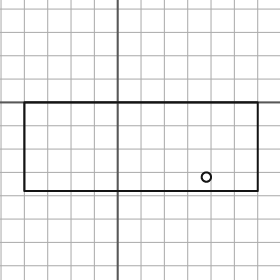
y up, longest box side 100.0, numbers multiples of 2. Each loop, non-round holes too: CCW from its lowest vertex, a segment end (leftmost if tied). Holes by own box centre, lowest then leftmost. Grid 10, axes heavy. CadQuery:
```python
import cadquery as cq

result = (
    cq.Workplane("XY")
    .moveTo(-40.0, -38.0)
    .lineTo(60.0, -38.0)
    .lineTo(60.0, 0.0)
    .lineTo(-40.0, 0.0)
    .close()
    .moveTo(38.0, -32.0)
    .circle(2.0)
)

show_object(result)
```